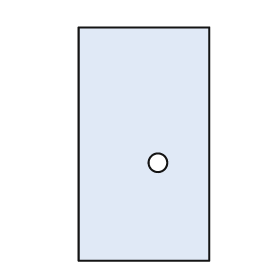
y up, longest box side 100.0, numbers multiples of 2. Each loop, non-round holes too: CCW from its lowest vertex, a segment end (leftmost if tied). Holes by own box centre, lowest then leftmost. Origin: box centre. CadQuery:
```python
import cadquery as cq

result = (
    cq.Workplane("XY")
    .moveTo(-28.0, -50.0)
    .lineTo(28.0, -50.0)
    .lineTo(28.0, 50.0)
    .lineTo(-28.0, 50.0)
    .close()
    .moveTo(6.0, -8.0)
    .circle(4.0)
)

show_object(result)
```